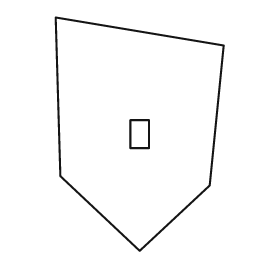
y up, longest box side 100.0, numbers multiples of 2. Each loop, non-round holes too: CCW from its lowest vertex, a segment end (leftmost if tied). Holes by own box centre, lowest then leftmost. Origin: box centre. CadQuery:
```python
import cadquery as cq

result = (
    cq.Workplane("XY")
    .moveTo(0.0, -50.0)
    .lineTo(30.0, -22.0)
    .lineTo(36.0, 38.0)
    .lineTo(-36.0, 50.0)
    .lineTo(-34.0, -18.0)
    .close()
    .moveTo(-4.0, -6.0)
    .lineTo(4.0, -6.0)
    .lineTo(4.0, 6.0)
    .lineTo(-4.0, 6.0)
    .close()
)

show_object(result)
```